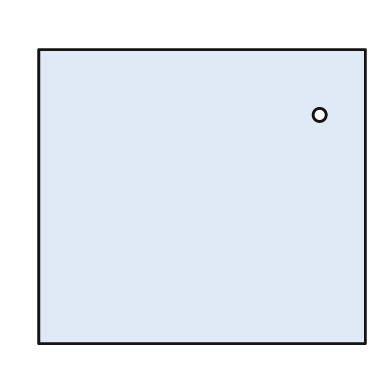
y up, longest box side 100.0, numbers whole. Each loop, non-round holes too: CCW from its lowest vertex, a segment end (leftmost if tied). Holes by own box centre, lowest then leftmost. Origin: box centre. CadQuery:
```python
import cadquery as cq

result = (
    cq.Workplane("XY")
    .moveTo(-50.0, -45.0)
    .lineTo(50.0, -45.0)
    .lineTo(50.0, 45.0)
    .lineTo(-50.0, 45.0)
    .close()
    .moveTo(36.0, 25.0)
    .circle(2.0)
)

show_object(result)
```